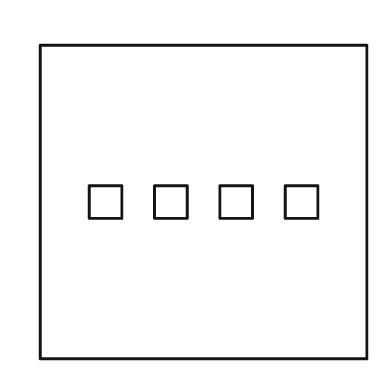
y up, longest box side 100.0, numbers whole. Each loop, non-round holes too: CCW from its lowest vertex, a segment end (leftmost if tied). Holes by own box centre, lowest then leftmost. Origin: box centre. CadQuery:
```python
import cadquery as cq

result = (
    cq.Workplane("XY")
    .moveTo(-50.0, -48.0)
    .lineTo(50.0, -48.0)
    .lineTo(50.0, 48.0)
    .lineTo(-50.0, 48.0)
    .close()
    .moveTo(-35.0, -5.0)
    .lineTo(-25.0, -5.0)
    .lineTo(-25.0, 5.0)
    .lineTo(-35.0, 5.0)
    .close()
    .moveTo(-15.0, -5.0)
    .lineTo(-5.0, -5.0)
    .lineTo(-5.0, 5.0)
    .lineTo(-15.0, 5.0)
    .close()
    .moveTo(5.0, -5.0)
    .lineTo(15.0, -5.0)
    .lineTo(15.0, 5.0)
    .lineTo(5.0, 5.0)
    .close()
    .moveTo(25.0, -5.0)
    .lineTo(35.0, -5.0)
    .lineTo(35.0, 5.0)
    .lineTo(25.0, 5.0)
    .close()
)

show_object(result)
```